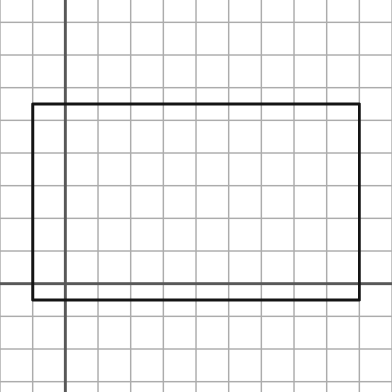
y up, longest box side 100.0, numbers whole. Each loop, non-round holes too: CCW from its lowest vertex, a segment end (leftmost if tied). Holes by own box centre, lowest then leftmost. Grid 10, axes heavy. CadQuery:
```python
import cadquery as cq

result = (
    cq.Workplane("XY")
    .moveTo(-10.0, -5.0)
    .lineTo(90.0, -5.0)
    .lineTo(90.0, 55.0)
    .lineTo(-10.0, 55.0)
    .close()
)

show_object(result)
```